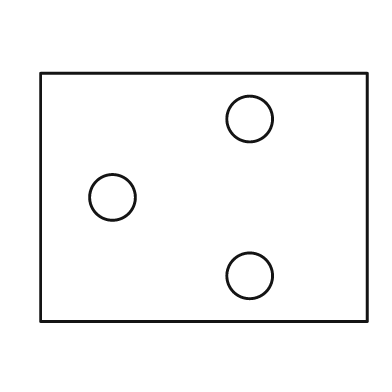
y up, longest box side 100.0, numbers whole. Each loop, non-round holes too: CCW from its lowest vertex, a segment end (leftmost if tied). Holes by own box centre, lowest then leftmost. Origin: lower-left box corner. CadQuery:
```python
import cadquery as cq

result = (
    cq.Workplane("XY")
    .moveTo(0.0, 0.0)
    .lineTo(100.0, 0.0)
    .lineTo(100.0, 76.0)
    .lineTo(0.0, 76.0)
    .close()
    .moveTo(64.0, 14.0)
    .circle(7.0)
    .moveTo(22.0, 38.0)
    .circle(7.0)
    .moveTo(64.0, 62.0)
    .circle(7.0)
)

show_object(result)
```